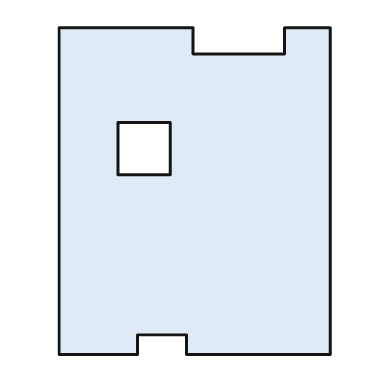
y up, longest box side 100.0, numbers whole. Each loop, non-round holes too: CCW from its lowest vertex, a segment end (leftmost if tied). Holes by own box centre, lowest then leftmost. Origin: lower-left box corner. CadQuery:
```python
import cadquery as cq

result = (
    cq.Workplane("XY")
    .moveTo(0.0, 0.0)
    .lineTo(24.0, 0.0)
    .lineTo(24.0, 6.0)
    .lineTo(39.0, 6.0)
    .lineTo(39.0, 0.0)
    .lineTo(83.0, 0.0)
    .lineTo(83.0, 100.0)
    .lineTo(69.0, 100.0)
    .lineTo(69.0, 92.0)
    .lineTo(41.0, 92.0)
    .lineTo(41.0, 100.0)
    .lineTo(0.0, 100.0)
    .close()
    .moveTo(18.0, 55.0)
    .lineTo(34.0, 55.0)
    .lineTo(34.0, 71.0)
    .lineTo(18.0, 71.0)
    .close()
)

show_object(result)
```